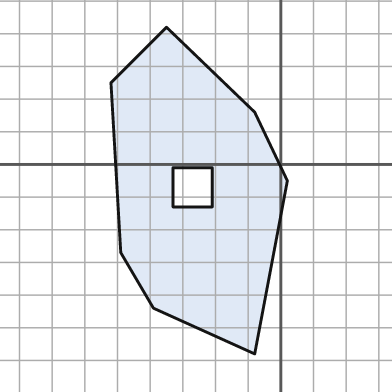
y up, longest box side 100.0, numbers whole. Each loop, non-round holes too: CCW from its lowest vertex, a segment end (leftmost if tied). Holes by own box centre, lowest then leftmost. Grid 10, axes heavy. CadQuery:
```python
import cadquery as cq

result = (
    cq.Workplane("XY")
    .moveTo(-8.0, -58.0)
    .lineTo(2.0, -5.0)
    .lineTo(-8.0, 16.0)
    .lineTo(-35.0, 42.0)
    .lineTo(-52.0, 25.0)
    .lineTo(-49.0, -27.0)
    .lineTo(-39.0, -44.0)
    .close()
    .moveTo(-33.0, -13.0)
    .lineTo(-21.0, -13.0)
    .lineTo(-21.0, -1.0)
    .lineTo(-33.0, -1.0)
    .close()
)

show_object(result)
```